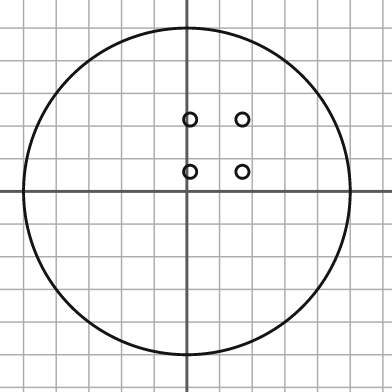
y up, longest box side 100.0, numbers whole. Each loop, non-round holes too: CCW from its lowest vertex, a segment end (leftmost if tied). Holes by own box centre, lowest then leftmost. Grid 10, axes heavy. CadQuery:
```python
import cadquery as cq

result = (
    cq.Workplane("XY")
    .moveTo(0.0, 0.0)
    .circle(50.0)
    .moveTo(1.0, 6.0)
    .circle(2.0)
    .moveTo(17.0, 6.0)
    .circle(2.0)
    .moveTo(1.0, 22.0)
    .circle(2.0)
    .moveTo(17.0, 22.0)
    .circle(2.0)
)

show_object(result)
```